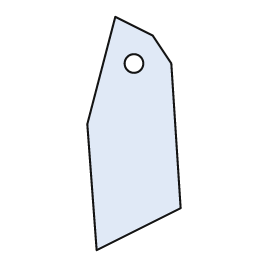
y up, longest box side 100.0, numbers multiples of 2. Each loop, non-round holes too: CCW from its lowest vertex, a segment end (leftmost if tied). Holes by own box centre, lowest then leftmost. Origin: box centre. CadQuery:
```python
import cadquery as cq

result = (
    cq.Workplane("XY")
    .moveTo(-16.0, -50.0)
    .lineTo(20.0, -32.0)
    .lineTo(16.0, 30.0)
    .lineTo(8.0, 42.0)
    .lineTo(-8.0, 50.0)
    .lineTo(-20.0, 4.0)
    .close()
    .moveTo(0.0, 30.0)
    .circle(4.0)
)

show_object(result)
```